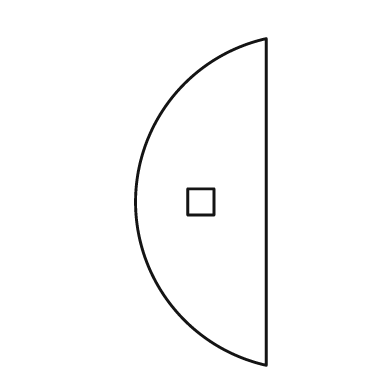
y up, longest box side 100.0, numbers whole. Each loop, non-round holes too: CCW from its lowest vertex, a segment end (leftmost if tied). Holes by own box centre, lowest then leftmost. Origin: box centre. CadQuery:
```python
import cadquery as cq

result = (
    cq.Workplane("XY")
    .moveTo(20.0, -50.0)
    .lineTo(20.0, 50.0)
    .threePointArc((-20.0, 0.0), (20.0, -50.0))
    .close()
    .moveTo(-4.0, -4.0)
    .lineTo(4.0, -4.0)
    .lineTo(4.0, 4.0)
    .lineTo(-4.0, 4.0)
    .close()
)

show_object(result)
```